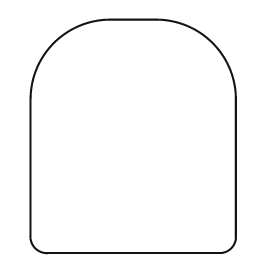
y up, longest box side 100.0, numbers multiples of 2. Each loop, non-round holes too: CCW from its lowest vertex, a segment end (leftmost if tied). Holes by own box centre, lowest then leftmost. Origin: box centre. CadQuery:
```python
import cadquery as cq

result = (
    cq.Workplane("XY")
    .moveTo(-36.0, -50.0)
    .lineTo(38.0, -50.0)
    .threePointArc((42.0, -48.0), (44.0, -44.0))
    .lineTo(44.0, 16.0)
    .threePointArc((34.0, 40.0), (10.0, 50.0))
    .lineTo(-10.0, 50.0)
    .threePointArc((-34.0, 40.0), (-44.0, 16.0))
    .lineTo(-44.0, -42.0)
    .threePointArc((-42.0, -48.0), (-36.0, -50.0))
    .close()
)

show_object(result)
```